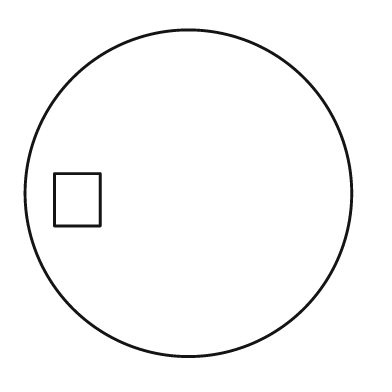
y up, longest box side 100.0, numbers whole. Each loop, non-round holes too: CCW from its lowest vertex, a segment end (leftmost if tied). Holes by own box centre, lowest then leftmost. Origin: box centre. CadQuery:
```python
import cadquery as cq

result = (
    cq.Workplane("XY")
    .moveTo(0.0, 0.0)
    .circle(50.0)
    .moveTo(-41.0, -10.0)
    .lineTo(-27.0, -10.0)
    .lineTo(-27.0, 6.0)
    .lineTo(-41.0, 6.0)
    .close()
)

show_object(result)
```